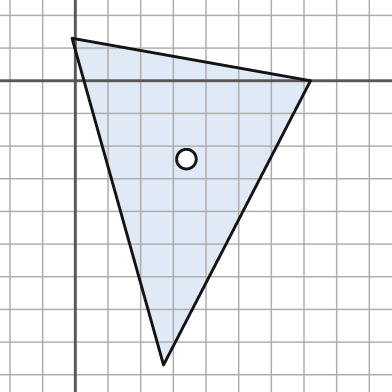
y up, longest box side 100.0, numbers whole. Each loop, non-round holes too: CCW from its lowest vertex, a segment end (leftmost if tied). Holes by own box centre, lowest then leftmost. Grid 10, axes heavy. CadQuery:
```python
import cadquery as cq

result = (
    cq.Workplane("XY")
    .moveTo(27.0, -87.0)
    .lineTo(72.0, 0.0)
    .lineTo(-1.0, 13.0)
    .close()
    .moveTo(34.0, -24.0)
    .circle(3.0)
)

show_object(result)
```